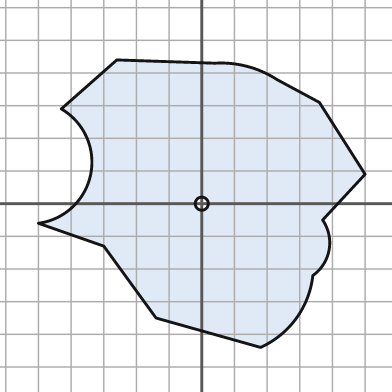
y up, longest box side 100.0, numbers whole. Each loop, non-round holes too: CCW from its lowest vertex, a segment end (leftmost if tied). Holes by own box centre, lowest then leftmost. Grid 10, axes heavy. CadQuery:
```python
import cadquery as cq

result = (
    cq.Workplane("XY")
    .moveTo(18.0, -44.0)
    .threePointArc((29.0, -35.0), (34.0, -22.0))
    .threePointArc((39.0, -14.0), (37.0, -5.0))
    .lineTo(50.0, 9.0)
    .lineTo(36.0, 31.0)
    .lineTo(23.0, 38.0)
    .threePointArc((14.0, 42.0), (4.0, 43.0))
    .lineTo(-26.0, 44.0)
    .lineTo(-43.0, 29.0)
    .threePointArc((-34.0, 9.0), (-50.0, -6.0))
    .lineTo(-30.0, -13.0)
    .lineTo(-14.0, -35.0)
    .close()
    .moveTo(0.0, 0.0)
    .circle(2.0)
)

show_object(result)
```